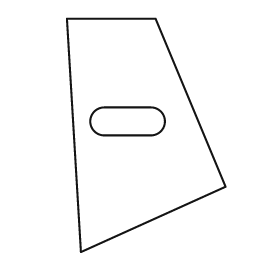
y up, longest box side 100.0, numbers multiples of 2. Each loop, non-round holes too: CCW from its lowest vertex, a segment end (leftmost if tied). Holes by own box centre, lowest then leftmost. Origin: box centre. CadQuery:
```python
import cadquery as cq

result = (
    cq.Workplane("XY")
    .moveTo(-28.0, -50.0)
    .lineTo(34.0, -22.0)
    .lineTo(4.0, 50.0)
    .lineTo(-34.0, 50.0)
    .close()
    .moveTo(-18.0, 0.0)
    .lineTo(2.0, 0.0)
    .threePointArc((8.0, 6.0), (2.0, 12.0))
    .lineTo(-18.0, 12.0)
    .threePointArc((-24.0, 6.0), (-18.0, 0.0))
    .close()
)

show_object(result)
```